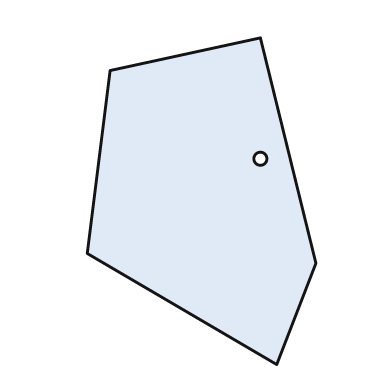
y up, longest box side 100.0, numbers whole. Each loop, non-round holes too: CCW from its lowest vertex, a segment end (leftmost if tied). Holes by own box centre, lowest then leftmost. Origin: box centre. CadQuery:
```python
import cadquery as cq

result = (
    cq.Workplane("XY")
    .moveTo(23.0, -50.0)
    .lineTo(35.0, -19.0)
    .lineTo(18.0, 50.0)
    .lineTo(-28.0, 40.0)
    .lineTo(-35.0, -16.0)
    .close()
    .moveTo(18.0, 13.0)
    .circle(2.0)
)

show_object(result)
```